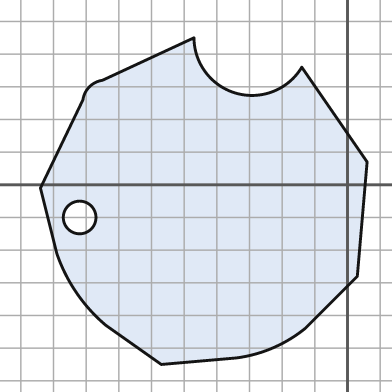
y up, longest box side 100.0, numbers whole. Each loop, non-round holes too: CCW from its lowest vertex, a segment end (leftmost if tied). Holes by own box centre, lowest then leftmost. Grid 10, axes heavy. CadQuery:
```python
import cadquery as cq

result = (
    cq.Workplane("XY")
    .moveTo(-57.0, -55.0)
    .lineTo(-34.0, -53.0)
    .threePointArc((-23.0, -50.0), (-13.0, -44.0))
    .lineTo(3.0, -28.0)
    .lineTo(6.0, 7.0)
    .lineTo(-14.0, 36.0)
    .threePointArc((-34.0, 28.0), (-47.0, 45.0))
    .lineTo(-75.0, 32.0)
    .threePointArc((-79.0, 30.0), (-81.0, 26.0))
    .lineTo(-94.0, -1.0)
    .lineTo(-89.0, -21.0)
    .threePointArc((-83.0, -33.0), (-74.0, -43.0))
    .close()
    .moveTo(-82.0, -10.0)
    .circle(5.0)
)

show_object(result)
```